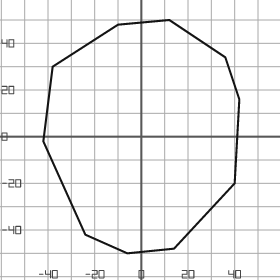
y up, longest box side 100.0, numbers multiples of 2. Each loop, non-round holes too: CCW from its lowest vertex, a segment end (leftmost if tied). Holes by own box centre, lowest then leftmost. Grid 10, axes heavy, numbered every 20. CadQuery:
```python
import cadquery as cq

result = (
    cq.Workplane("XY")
    .moveTo(-6.0, -50.0)
    .lineTo(14.0, -48.0)
    .lineTo(40.0, -20.0)
    .lineTo(42.0, 16.0)
    .lineTo(36.0, 34.0)
    .lineTo(12.0, 50.0)
    .lineTo(-10.0, 48.0)
    .lineTo(-38.0, 30.0)
    .lineTo(-42.0, -2.0)
    .lineTo(-24.0, -42.0)
    .close()
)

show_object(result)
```